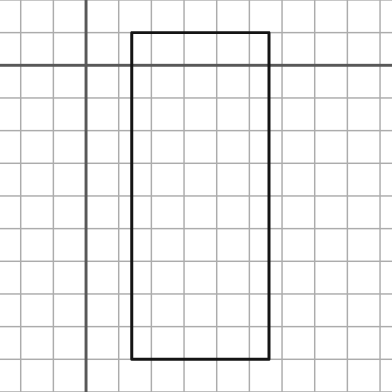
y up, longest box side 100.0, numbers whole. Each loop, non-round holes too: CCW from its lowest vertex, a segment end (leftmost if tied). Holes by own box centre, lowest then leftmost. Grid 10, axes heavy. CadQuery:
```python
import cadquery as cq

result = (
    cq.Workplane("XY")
    .moveTo(14.0, -90.0)
    .lineTo(56.0, -90.0)
    .lineTo(56.0, 10.0)
    .lineTo(14.0, 10.0)
    .close()
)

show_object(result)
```